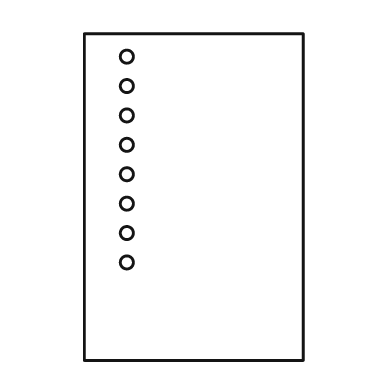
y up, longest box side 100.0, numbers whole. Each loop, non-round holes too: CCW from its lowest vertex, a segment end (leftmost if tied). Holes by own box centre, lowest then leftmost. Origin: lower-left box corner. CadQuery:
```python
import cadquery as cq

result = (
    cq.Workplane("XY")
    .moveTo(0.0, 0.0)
    .lineTo(67.0, 0.0)
    .lineTo(67.0, 100.0)
    .lineTo(0.0, 100.0)
    .close()
    .moveTo(13.0, 30.0)
    .circle(2.0)
    .moveTo(13.0, 39.0)
    .circle(2.0)
    .moveTo(13.0, 48.0)
    .circle(2.0)
    .moveTo(13.0, 57.0)
    .circle(2.0)
    .moveTo(13.0, 66.0)
    .circle(2.0)
    .moveTo(13.0, 75.0)
    .circle(2.0)
    .moveTo(13.0, 84.0)
    .circle(2.0)
    .moveTo(13.0, 93.0)
    .circle(2.0)
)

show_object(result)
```